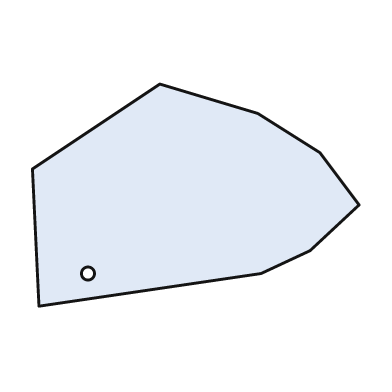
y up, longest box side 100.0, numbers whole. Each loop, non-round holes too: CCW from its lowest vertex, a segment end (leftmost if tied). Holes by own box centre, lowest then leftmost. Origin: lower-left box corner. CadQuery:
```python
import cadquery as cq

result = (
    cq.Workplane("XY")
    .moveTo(2.0, 0.0)
    .lineTo(70.0, 10.0)
    .lineTo(85.0, 17.0)
    .lineTo(100.0, 31.0)
    .lineTo(88.0, 47.0)
    .lineTo(69.0, 59.0)
    .lineTo(39.0, 68.0)
    .lineTo(0.0, 42.0)
    .close()
    .moveTo(17.0, 10.0)
    .circle(2.0)
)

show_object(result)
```